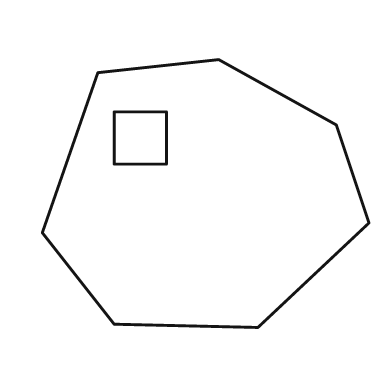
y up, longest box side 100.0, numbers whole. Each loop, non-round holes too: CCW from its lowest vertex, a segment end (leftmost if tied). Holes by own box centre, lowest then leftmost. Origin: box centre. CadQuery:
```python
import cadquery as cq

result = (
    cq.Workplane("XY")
    .moveTo(16.0, -41.0)
    .lineTo(50.0, -9.0)
    .lineTo(40.0, 21.0)
    .lineTo(4.0, 41.0)
    .lineTo(-33.0, 37.0)
    .lineTo(-50.0, -12.0)
    .lineTo(-28.0, -40.0)
    .close()
    .moveTo(-28.0, 9.0)
    .lineTo(-12.0, 9.0)
    .lineTo(-12.0, 25.0)
    .lineTo(-28.0, 25.0)
    .close()
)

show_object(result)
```